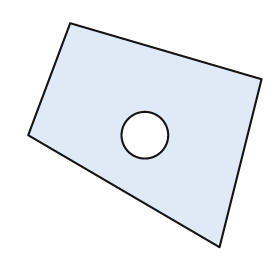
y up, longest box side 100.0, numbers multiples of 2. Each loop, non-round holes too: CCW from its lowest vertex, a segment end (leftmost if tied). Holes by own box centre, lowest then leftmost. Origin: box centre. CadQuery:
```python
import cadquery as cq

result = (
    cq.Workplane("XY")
    .moveTo(32.0, -48.0)
    .lineTo(50.0, 24.0)
    .lineTo(-32.0, 48.0)
    .lineTo(-50.0, 0.0)
    .close()
    .moveTo(0.0, 0.0)
    .circle(10.0)
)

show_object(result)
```